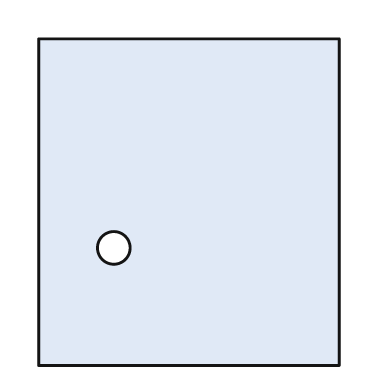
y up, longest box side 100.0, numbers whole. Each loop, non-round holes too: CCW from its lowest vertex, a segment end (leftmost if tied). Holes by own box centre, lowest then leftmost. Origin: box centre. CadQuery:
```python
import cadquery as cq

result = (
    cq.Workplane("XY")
    .moveTo(-46.0, -50.0)
    .lineTo(46.0, -50.0)
    .lineTo(46.0, 50.0)
    .lineTo(-46.0, 50.0)
    .close()
    .moveTo(-23.0, -14.0)
    .circle(5.0)
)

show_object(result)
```